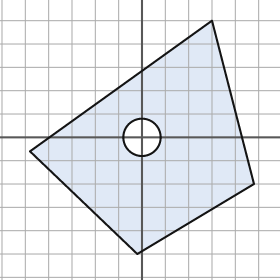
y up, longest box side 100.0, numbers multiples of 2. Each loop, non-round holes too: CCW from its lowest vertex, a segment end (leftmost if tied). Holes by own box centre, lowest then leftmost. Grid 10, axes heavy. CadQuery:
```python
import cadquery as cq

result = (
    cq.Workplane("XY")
    .moveTo(-2.0, -50.0)
    .lineTo(48.0, -20.0)
    .lineTo(30.0, 50.0)
    .lineTo(-48.0, -6.0)
    .close()
    .moveTo(0.0, 0.0)
    .circle(8.0)
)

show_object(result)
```